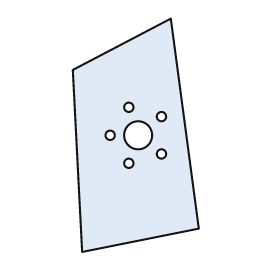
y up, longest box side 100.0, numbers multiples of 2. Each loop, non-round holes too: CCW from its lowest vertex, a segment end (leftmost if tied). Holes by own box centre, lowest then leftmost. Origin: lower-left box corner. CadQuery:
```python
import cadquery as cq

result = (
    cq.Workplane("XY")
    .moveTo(4.0, 0.0)
    .lineTo(54.0, 10.0)
    .lineTo(42.0, 100.0)
    .lineTo(0.0, 78.0)
    .close()
    .moveTo(24.0, 38.0)
    .circle(2.0)
    .moveTo(38.0, 42.0)
    .circle(2.0)
    .moveTo(16.0, 50.0)
    .circle(2.0)
    .moveTo(28.0, 50.0)
    .circle(6.0)
    .moveTo(38.0, 58.0)
    .circle(2.0)
    .moveTo(24.0, 62.0)
    .circle(2.0)
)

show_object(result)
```